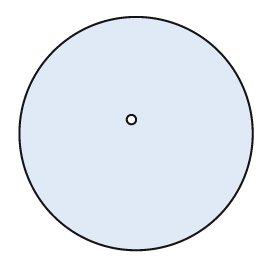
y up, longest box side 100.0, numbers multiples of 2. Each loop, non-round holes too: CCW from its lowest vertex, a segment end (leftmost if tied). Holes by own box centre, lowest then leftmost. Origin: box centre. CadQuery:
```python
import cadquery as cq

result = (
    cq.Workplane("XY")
    .moveTo(0.0, 0.0)
    .circle(50.0)
    .moveTo(-2.0, 6.0)
    .circle(2.0)
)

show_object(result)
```